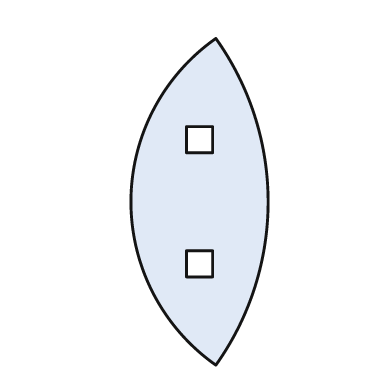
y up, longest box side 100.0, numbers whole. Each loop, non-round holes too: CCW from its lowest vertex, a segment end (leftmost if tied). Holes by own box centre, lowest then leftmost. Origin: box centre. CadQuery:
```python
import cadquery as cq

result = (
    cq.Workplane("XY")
    .moveTo(5.0, -50.0)
    .threePointArc((21.0, 0.0), (5.0, 50.0))
    .threePointArc((-21.0, 0.0), (5.0, -50.0))
    .close()
    .moveTo(-4.0, -23.0)
    .lineTo(4.0, -23.0)
    .lineTo(4.0, -15.0)
    .lineTo(-4.0, -15.0)
    .close()
    .moveTo(-4.0, 15.0)
    .lineTo(4.0, 15.0)
    .lineTo(4.0, 23.0)
    .lineTo(-4.0, 23.0)
    .close()
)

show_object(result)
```